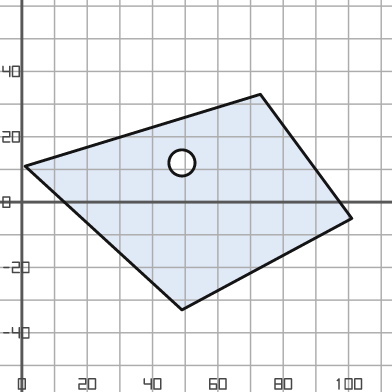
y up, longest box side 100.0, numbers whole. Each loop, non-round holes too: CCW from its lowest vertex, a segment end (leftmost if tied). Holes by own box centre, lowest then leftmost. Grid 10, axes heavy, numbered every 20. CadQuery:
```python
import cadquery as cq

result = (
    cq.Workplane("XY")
    .moveTo(49.0, -33.0)
    .lineTo(101.0, -5.0)
    .lineTo(73.0, 33.0)
    .lineTo(1.0, 11.0)
    .close()
    .moveTo(49.0, 12.0)
    .circle(4.0)
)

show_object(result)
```